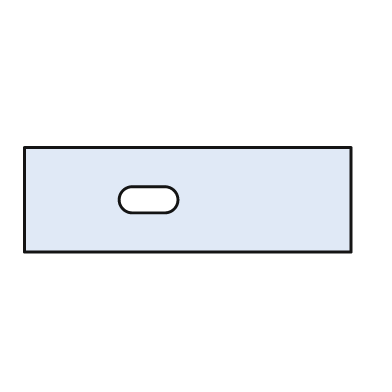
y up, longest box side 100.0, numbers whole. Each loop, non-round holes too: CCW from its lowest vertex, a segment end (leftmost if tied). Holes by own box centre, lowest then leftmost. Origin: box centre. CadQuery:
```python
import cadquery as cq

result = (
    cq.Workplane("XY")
    .moveTo(-50.0, -16.0)
    .lineTo(50.0, -16.0)
    .lineTo(50.0, 16.0)
    .lineTo(-50.0, 16.0)
    .close()
    .moveTo(-17.0, -4.0)
    .lineTo(-7.0, -4.0)
    .threePointArc((-3.0, 0.0), (-7.0, 4.0))
    .lineTo(-17.0, 4.0)
    .threePointArc((-21.0, 0.0), (-17.0, -4.0))
    .close()
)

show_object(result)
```